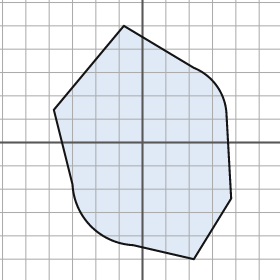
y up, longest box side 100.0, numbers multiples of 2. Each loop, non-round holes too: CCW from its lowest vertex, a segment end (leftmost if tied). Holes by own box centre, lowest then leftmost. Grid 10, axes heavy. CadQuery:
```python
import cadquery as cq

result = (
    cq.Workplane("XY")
    .moveTo(22.0, -50.0)
    .lineTo(38.0, -24.0)
    .lineTo(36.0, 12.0)
    .threePointArc((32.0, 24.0), (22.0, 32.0))
    .lineTo(-8.0, 50.0)
    .lineTo(-38.0, 14.0)
    .lineTo(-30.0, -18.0)
    .threePointArc((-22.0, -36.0), (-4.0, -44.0))
    .close()
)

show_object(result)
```